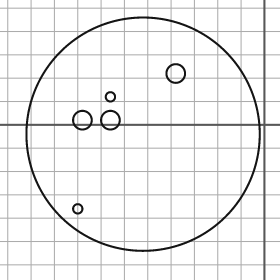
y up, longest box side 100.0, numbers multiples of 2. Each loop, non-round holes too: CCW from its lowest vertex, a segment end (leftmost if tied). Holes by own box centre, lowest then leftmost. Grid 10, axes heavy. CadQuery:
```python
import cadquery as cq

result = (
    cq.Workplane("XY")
    .moveTo(-52.0, -4.0)
    .circle(50.0)
    .moveTo(-80.0, -36.0)
    .circle(2.0)
    .moveTo(-78.0, 2.0)
    .circle(4.0)
    .moveTo(-66.0, 2.0)
    .circle(4.0)
    .moveTo(-66.0, 12.0)
    .circle(2.0)
    .moveTo(-38.0, 22.0)
    .circle(4.0)
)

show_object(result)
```